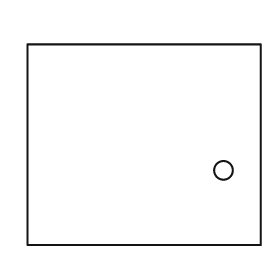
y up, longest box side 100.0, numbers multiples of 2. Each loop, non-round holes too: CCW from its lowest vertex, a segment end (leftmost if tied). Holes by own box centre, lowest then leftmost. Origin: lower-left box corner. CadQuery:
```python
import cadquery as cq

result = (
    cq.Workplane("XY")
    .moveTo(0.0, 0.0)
    .lineTo(100.0, 0.0)
    .lineTo(100.0, 86.0)
    .lineTo(0.0, 86.0)
    .close()
    .moveTo(84.0, 32.0)
    .circle(4.0)
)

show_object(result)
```